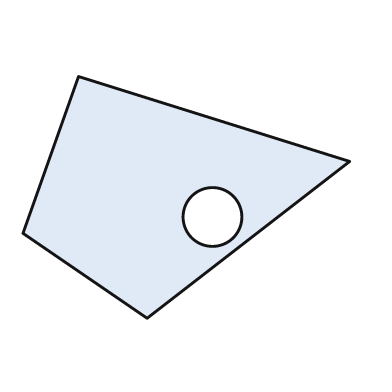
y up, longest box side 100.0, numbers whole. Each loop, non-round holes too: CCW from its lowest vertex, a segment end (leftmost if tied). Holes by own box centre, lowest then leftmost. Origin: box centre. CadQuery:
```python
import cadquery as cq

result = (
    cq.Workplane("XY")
    .moveTo(-12.0, -37.0)
    .lineTo(50.0, 11.0)
    .lineTo(-33.0, 37.0)
    .lineTo(-50.0, -11.0)
    .close()
    .moveTo(8.0, -6.0)
    .circle(9.0)
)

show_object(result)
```